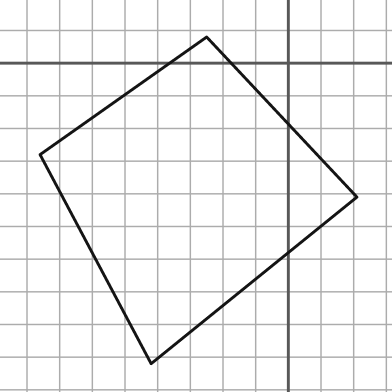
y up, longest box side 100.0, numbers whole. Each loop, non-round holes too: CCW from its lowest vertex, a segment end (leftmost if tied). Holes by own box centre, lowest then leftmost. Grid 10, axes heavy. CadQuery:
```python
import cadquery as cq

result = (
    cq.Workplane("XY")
    .moveTo(-42.0, -92.0)
    .lineTo(21.0, -41.0)
    .lineTo(-25.0, 8.0)
    .lineTo(-76.0, -28.0)
    .close()
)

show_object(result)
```